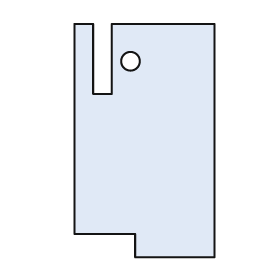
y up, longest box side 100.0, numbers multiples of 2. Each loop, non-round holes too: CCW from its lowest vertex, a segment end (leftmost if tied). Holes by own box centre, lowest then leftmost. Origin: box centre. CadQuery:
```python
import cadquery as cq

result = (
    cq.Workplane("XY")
    .moveTo(-4.0, -50.0)
    .lineTo(30.0, -50.0)
    .lineTo(30.0, 50.0)
    .lineTo(-14.0, 50.0)
    .lineTo(-14.0, 20.0)
    .lineTo(-22.0, 20.0)
    .lineTo(-22.0, 50.0)
    .lineTo(-30.0, 50.0)
    .lineTo(-30.0, -40.0)
    .lineTo(-4.0, -40.0)
    .close()
    .moveTo(-6.0, 34.0)
    .circle(4.0)
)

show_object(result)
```